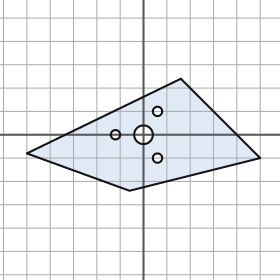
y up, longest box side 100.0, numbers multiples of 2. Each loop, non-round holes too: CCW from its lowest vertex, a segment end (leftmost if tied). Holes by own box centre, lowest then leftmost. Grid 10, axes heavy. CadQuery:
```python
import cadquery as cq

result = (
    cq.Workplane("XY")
    .moveTo(-6.0, -24.0)
    .lineTo(50.0, -10.0)
    .lineTo(16.0, 24.0)
    .lineTo(-50.0, -8.0)
    .close()
    .moveTo(6.0, -10.0)
    .circle(2.0)
    .moveTo(-12.0, 0.0)
    .circle(2.0)
    .moveTo(0.0, 0.0)
    .circle(4.0)
    .moveTo(6.0, 10.0)
    .circle(2.0)
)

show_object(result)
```